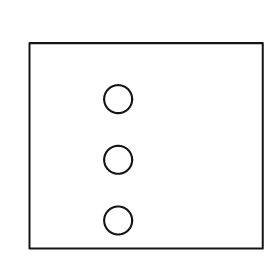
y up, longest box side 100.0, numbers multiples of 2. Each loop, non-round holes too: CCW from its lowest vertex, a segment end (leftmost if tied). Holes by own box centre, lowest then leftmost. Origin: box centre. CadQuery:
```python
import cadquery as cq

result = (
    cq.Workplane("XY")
    .moveTo(-50.0, -44.0)
    .lineTo(50.0, -44.0)
    .lineTo(50.0, 44.0)
    .lineTo(-50.0, 44.0)
    .close()
    .moveTo(-12.0, -32.0)
    .circle(6.0)
    .moveTo(-12.0, -6.0)
    .circle(6.0)
    .moveTo(-12.0, 20.0)
    .circle(6.0)
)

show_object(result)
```